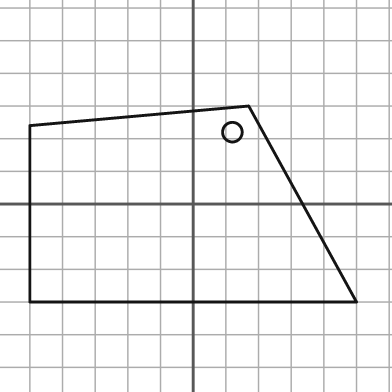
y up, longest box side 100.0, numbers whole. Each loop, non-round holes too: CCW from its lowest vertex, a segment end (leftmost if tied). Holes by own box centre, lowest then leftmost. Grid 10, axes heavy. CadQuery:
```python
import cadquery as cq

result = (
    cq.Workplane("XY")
    .moveTo(-50.0, -30.0)
    .lineTo(50.0, -30.0)
    .lineTo(17.0, 30.0)
    .lineTo(-50.0, 24.0)
    .close()
    .moveTo(12.0, 22.0)
    .circle(3.0)
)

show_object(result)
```